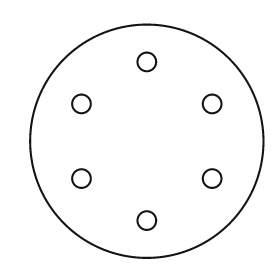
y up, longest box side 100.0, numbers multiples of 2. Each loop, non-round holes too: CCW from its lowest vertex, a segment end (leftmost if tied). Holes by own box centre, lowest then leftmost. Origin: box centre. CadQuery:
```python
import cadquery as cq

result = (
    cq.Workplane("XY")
    .moveTo(0.0, 0.0)
    .circle(50.0)
    .moveTo(0.0, -34.0)
    .circle(4.0)
    .moveTo(-28.0, -16.0)
    .circle(4.0)
    .moveTo(28.0, -16.0)
    .circle(4.0)
    .moveTo(-28.0, 16.0)
    .circle(4.0)
    .moveTo(28.0, 16.0)
    .circle(4.0)
    .moveTo(0.0, 34.0)
    .circle(4.0)
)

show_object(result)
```